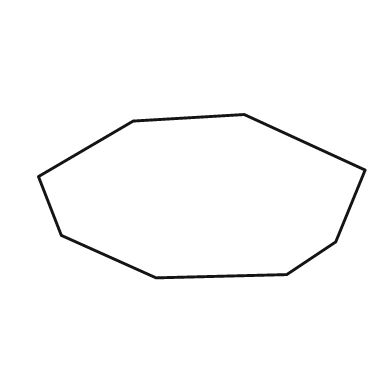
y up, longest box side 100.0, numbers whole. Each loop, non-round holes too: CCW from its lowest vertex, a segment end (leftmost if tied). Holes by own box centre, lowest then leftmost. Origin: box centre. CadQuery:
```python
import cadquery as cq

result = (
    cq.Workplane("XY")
    .moveTo(-14.0, -25.0)
    .lineTo(26.0, -24.0)
    .lineTo(41.0, -14.0)
    .lineTo(50.0, 8.0)
    .lineTo(13.0, 25.0)
    .lineTo(-21.0, 23.0)
    .lineTo(-50.0, 6.0)
    .lineTo(-43.0, -12.0)
    .close()
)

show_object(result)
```